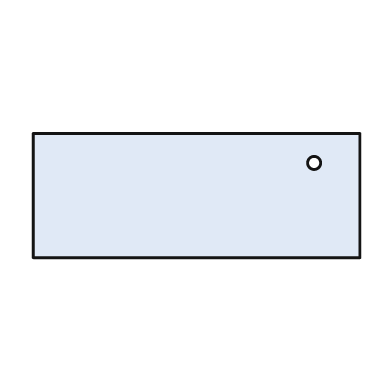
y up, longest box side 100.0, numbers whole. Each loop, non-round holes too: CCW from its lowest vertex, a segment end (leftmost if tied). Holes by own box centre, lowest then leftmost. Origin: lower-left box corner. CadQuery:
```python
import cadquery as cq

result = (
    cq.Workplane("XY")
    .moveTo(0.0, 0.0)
    .lineTo(100.0, 0.0)
    .lineTo(100.0, 38.0)
    .lineTo(0.0, 38.0)
    .close()
    .moveTo(86.0, 29.0)
    .circle(2.0)
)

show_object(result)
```